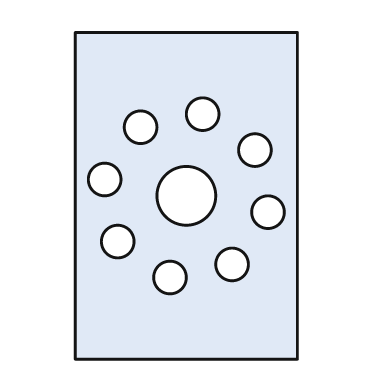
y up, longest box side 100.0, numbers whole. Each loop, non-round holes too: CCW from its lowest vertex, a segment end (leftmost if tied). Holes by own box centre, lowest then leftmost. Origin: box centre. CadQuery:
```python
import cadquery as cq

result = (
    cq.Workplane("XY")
    .moveTo(-34.0, -50.0)
    .lineTo(34.0, -50.0)
    .lineTo(34.0, 50.0)
    .lineTo(-34.0, 50.0)
    .close()
    .moveTo(-5.0, -25.0)
    .circle(5.0)
    .moveTo(14.0, -21.0)
    .circle(5.0)
    .moveTo(-21.0, -14.0)
    .circle(5.0)
    .moveTo(25.0, -5.0)
    .circle(5.0)
    .moveTo(0.0, 0.0)
    .circle(9.0)
    .moveTo(-25.0, 5.0)
    .circle(5.0)
    .moveTo(21.0, 14.0)
    .circle(5.0)
    .moveTo(-14.0, 21.0)
    .circle(5.0)
    .moveTo(5.0, 25.0)
    .circle(5.0)
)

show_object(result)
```